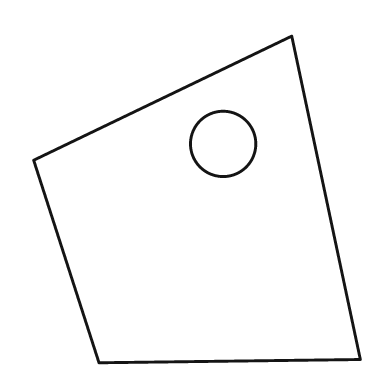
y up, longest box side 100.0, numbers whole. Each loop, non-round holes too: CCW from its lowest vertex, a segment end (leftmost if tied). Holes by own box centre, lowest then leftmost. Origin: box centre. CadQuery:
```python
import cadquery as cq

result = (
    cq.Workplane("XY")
    .moveTo(-30.0, -50.0)
    .lineTo(50.0, -49.0)
    .lineTo(29.0, 50.0)
    .lineTo(-50.0, 12.0)
    .close()
    .moveTo(8.0, 17.0)
    .circle(10.0)
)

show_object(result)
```